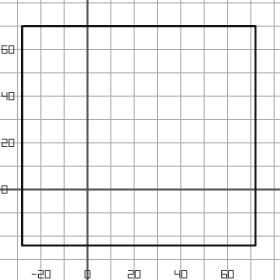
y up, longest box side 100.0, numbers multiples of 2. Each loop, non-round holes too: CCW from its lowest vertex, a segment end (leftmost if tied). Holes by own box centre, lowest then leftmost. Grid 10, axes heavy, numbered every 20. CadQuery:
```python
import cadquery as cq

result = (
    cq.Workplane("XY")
    .moveTo(-28.0, -24.0)
    .lineTo(72.0, -24.0)
    .lineTo(72.0, 70.0)
    .lineTo(-28.0, 70.0)
    .close()
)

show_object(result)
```